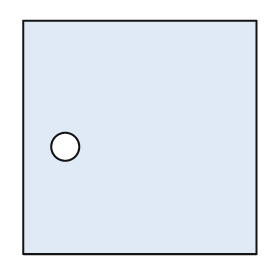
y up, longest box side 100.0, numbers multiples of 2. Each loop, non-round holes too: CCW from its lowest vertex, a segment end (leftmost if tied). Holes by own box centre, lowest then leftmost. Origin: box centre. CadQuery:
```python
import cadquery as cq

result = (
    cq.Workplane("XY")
    .moveTo(-50.0, -50.0)
    .lineTo(50.0, -50.0)
    .lineTo(50.0, 50.0)
    .lineTo(-50.0, 50.0)
    .close()
    .moveTo(-32.0, -4.0)
    .circle(6.0)
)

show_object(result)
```